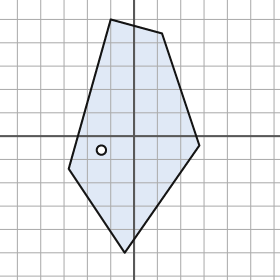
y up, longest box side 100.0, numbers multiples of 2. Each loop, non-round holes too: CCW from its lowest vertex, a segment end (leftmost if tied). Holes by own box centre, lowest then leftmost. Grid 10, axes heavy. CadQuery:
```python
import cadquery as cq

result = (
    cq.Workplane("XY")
    .moveTo(-4.0, -50.0)
    .lineTo(28.0, -4.0)
    .lineTo(12.0, 44.0)
    .lineTo(-10.0, 50.0)
    .lineTo(-28.0, -14.0)
    .close()
    .moveTo(-14.0, -6.0)
    .circle(2.0)
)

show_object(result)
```